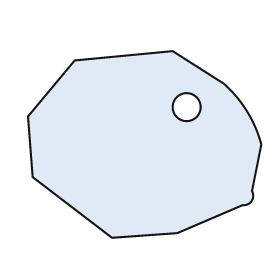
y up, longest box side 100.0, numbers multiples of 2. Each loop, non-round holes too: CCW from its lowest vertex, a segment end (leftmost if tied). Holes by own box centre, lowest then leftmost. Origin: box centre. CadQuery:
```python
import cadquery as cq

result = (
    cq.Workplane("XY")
    .moveTo(-14.0, -40.0)
    .lineTo(14.0, -38.0)
    .lineTo(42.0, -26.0)
    .threePointArc((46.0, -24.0), (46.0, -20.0))
    .lineTo(50.0, 0.0)
    .threePointArc((44.0, 14.0), (34.0, 26.0))
    .lineTo(12.0, 40.0)
    .lineTo(-30.0, 36.0)
    .lineTo(-50.0, 12.0)
    .lineTo(-48.0, -14.0)
    .close()
    .moveTo(18.0, 16.0)
    .circle(6.0)
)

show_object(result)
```